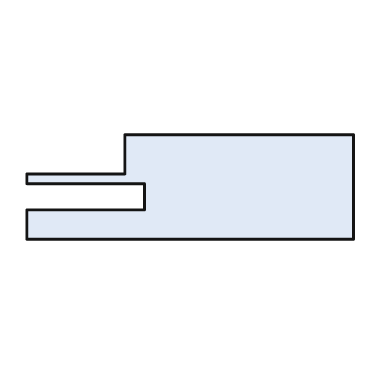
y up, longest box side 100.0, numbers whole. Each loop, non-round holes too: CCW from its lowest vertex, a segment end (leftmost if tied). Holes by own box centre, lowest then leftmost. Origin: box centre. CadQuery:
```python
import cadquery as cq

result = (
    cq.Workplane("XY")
    .moveTo(-50.0, -16.0)
    .lineTo(50.0, -16.0)
    .lineTo(50.0, 16.0)
    .lineTo(-20.0, 16.0)
    .lineTo(-20.0, 4.0)
    .lineTo(-50.0, 4.0)
    .lineTo(-50.0, 1.0)
    .lineTo(-14.0, 1.0)
    .lineTo(-14.0, -7.0)
    .lineTo(-50.0, -7.0)
    .close()
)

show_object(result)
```